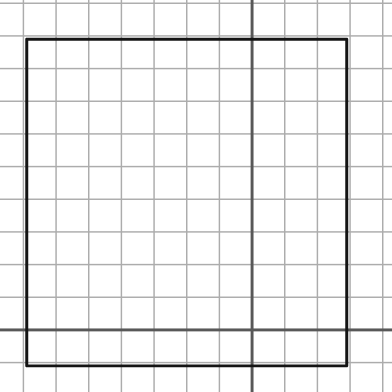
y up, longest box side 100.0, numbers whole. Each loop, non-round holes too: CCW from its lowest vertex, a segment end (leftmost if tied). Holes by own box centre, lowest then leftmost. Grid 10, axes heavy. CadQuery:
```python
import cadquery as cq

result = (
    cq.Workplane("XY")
    .moveTo(-69.0, -11.0)
    .lineTo(29.0, -11.0)
    .lineTo(29.0, 89.0)
    .lineTo(-69.0, 89.0)
    .close()
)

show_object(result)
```